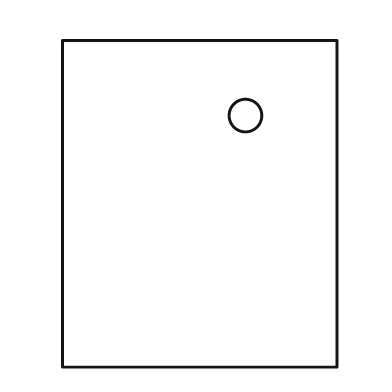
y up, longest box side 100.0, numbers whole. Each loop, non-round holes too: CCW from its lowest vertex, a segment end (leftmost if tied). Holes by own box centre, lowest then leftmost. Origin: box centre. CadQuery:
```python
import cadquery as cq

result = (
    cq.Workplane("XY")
    .moveTo(-42.0, -50.0)
    .lineTo(42.0, -50.0)
    .lineTo(42.0, 50.0)
    .lineTo(-42.0, 50.0)
    .close()
    .moveTo(14.0, 27.0)
    .circle(5.0)
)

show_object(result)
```